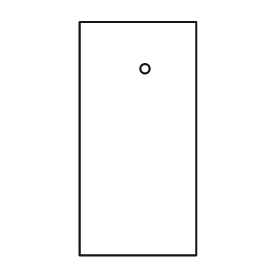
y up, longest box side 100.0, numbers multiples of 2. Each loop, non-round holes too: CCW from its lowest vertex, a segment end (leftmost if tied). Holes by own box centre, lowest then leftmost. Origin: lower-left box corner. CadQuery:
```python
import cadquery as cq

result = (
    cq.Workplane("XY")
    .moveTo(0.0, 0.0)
    .lineTo(50.0, 0.0)
    .lineTo(50.0, 100.0)
    .lineTo(0.0, 100.0)
    .close()
    .moveTo(28.0, 80.0)
    .circle(2.0)
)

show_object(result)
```